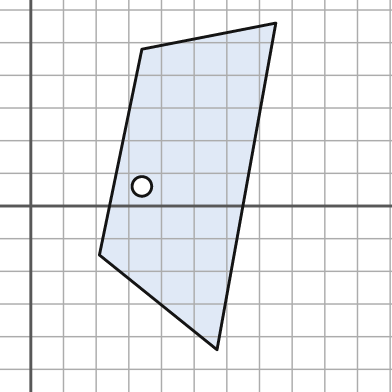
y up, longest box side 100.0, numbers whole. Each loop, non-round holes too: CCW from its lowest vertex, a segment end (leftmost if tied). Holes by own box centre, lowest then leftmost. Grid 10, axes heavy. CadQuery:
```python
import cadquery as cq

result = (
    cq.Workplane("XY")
    .moveTo(57.0, -44.0)
    .lineTo(75.0, 56.0)
    .lineTo(34.0, 48.0)
    .lineTo(21.0, -15.0)
    .close()
    .moveTo(34.0, 6.0)
    .circle(3.0)
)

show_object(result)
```